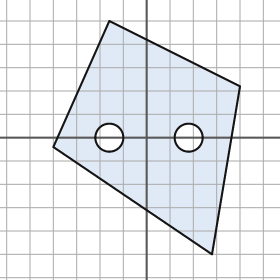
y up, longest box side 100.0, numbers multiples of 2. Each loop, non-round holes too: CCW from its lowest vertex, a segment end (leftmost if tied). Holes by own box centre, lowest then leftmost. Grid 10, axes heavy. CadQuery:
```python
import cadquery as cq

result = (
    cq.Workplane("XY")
    .moveTo(28.0, -50.0)
    .lineTo(40.0, 22.0)
    .lineTo(-16.0, 50.0)
    .lineTo(-40.0, -4.0)
    .close()
    .moveTo(-16.0, 0.0)
    .circle(6.0)
    .moveTo(18.0, 0.0)
    .circle(6.0)
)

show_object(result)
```